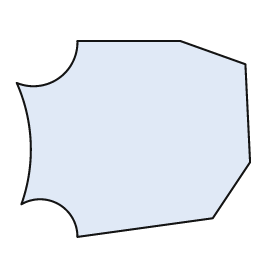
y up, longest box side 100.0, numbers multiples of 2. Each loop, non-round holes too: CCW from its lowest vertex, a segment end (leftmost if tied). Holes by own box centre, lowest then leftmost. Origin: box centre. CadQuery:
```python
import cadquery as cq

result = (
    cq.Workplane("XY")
    .moveTo(-24.0, -42.0)
    .lineTo(34.0, -34.0)
    .lineTo(50.0, -10.0)
    .lineTo(48.0, 32.0)
    .lineTo(20.0, 42.0)
    .lineTo(-24.0, 42.0)
    .threePointArc((-32.0, 26.0), (-50.0, 24.0))
    .threePointArc((-44.0, -2.0), (-48.0, -28.0))
    .threePointArc((-32.0, -28.0), (-24.0, -42.0))
    .close()
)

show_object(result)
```